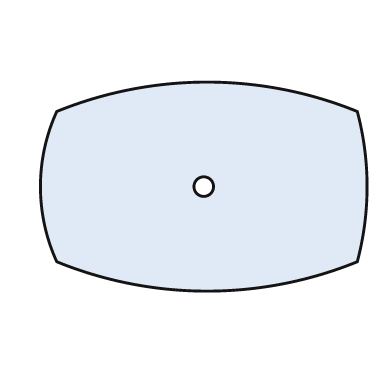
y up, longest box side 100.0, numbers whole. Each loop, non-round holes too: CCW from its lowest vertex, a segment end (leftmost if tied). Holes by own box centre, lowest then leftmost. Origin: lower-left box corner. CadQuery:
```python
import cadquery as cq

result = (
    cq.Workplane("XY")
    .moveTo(5.0, 9.0)
    .threePointArc((51.0, 0.0), (97.0, 9.0))
    .threePointArc((100.0, 32.0), (97.0, 55.0))
    .threePointArc((51.0, 64.0), (5.0, 55.0))
    .threePointArc((0.0, 32.0), (5.0, 9.0))
    .close()
    .moveTo(50.0, 32.0)
    .circle(3.0)
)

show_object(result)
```